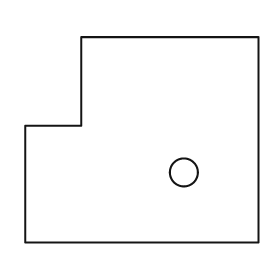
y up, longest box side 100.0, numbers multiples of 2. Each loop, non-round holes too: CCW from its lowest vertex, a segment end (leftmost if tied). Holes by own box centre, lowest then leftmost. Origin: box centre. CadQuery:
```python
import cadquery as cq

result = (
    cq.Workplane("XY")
    .moveTo(-50.0, -44.0)
    .lineTo(50.0, -44.0)
    .lineTo(50.0, 44.0)
    .lineTo(-26.0, 44.0)
    .lineTo(-26.0, 6.0)
    .lineTo(-50.0, 6.0)
    .close()
    .moveTo(18.0, -14.0)
    .circle(6.0)
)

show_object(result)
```